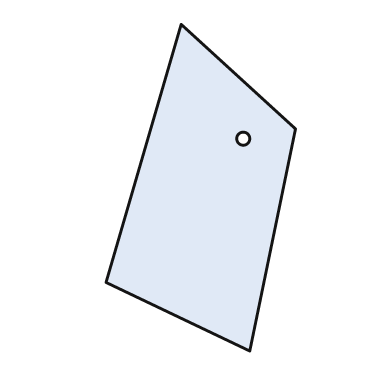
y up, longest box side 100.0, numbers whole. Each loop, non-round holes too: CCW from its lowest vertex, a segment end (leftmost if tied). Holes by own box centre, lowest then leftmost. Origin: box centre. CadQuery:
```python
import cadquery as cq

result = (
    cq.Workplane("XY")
    .moveTo(15.0, -50.0)
    .lineTo(29.0, 18.0)
    .lineTo(-6.0, 50.0)
    .lineTo(-29.0, -29.0)
    .close()
    .moveTo(13.0, 15.0)
    .circle(2.0)
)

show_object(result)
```